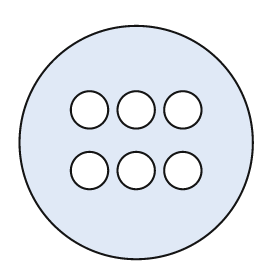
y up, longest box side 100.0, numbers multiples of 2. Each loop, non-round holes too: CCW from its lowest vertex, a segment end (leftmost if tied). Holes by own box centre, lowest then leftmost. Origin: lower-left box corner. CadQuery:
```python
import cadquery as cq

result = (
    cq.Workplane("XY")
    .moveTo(50.0, 50.0)
    .circle(50.0)
    .moveTo(30.0, 38.0)
    .circle(8.0)
    .moveTo(50.0, 38.0)
    .circle(8.0)
    .moveTo(70.0, 38.0)
    .circle(8.0)
    .moveTo(30.0, 64.0)
    .circle(8.0)
    .moveTo(50.0, 64.0)
    .circle(8.0)
    .moveTo(70.0, 64.0)
    .circle(8.0)
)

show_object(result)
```